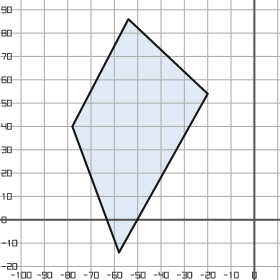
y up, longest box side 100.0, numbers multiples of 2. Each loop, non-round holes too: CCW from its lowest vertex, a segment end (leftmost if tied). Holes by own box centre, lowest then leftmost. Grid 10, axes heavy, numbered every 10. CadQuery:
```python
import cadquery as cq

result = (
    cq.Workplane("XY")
    .moveTo(-58.0, -14.0)
    .lineTo(-20.0, 54.0)
    .lineTo(-54.0, 86.0)
    .lineTo(-78.0, 40.0)
    .close()
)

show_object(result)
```